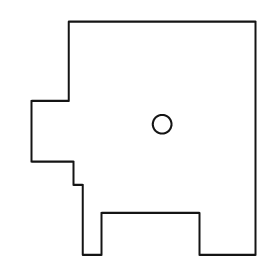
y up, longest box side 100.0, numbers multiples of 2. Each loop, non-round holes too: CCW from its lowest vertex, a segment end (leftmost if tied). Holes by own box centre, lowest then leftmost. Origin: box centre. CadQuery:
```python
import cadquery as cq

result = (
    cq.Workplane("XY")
    .moveTo(-26.0, -50.0)
    .lineTo(-18.0, -50.0)
    .lineTo(-18.0, -32.0)
    .lineTo(24.0, -32.0)
    .lineTo(24.0, -50.0)
    .lineTo(48.0, -50.0)
    .lineTo(48.0, 50.0)
    .lineTo(-32.0, 50.0)
    .lineTo(-32.0, 16.0)
    .lineTo(-48.0, 16.0)
    .lineTo(-48.0, -10.0)
    .lineTo(-30.0, -10.0)
    .lineTo(-30.0, -20.0)
    .lineTo(-26.0, -20.0)
    .close()
    .moveTo(8.0, 6.0)
    .circle(4.0)
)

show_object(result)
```